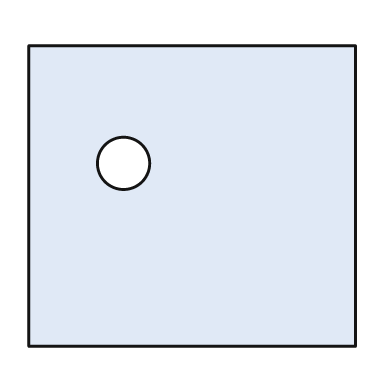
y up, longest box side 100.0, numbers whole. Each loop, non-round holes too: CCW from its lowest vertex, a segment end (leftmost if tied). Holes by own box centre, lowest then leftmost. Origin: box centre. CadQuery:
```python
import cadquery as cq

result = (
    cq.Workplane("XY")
    .moveTo(-50.0, -46.0)
    .lineTo(50.0, -46.0)
    .lineTo(50.0, 46.0)
    .lineTo(-50.0, 46.0)
    .close()
    .moveTo(-21.0, 10.0)
    .circle(8.0)
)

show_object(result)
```